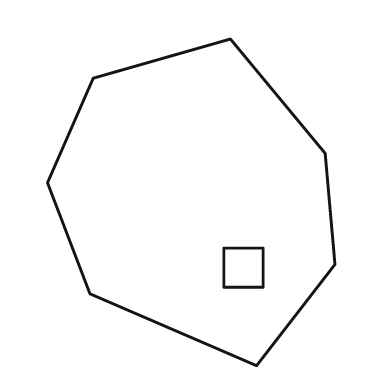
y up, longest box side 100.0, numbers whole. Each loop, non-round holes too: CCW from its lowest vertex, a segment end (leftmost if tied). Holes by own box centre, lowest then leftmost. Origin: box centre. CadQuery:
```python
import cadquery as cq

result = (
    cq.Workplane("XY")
    .moveTo(20.0, -50.0)
    .lineTo(44.0, -19.0)
    .lineTo(41.0, 15.0)
    .lineTo(12.0, 50.0)
    .lineTo(-30.0, 38.0)
    .lineTo(-44.0, 6.0)
    .lineTo(-31.0, -28.0)
    .close()
    .moveTo(10.0, -26.0)
    .lineTo(22.0, -26.0)
    .lineTo(22.0, -14.0)
    .lineTo(10.0, -14.0)
    .close()
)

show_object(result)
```